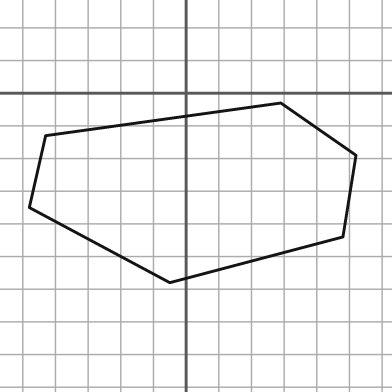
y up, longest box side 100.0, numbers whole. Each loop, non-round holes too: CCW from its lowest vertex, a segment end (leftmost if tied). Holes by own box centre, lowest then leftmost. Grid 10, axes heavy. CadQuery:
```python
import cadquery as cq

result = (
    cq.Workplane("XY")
    .moveTo(-5.0, -58.0)
    .lineTo(48.0, -44.0)
    .lineTo(52.0, -19.0)
    .lineTo(29.0, -3.0)
    .lineTo(-43.0, -13.0)
    .lineTo(-48.0, -35.0)
    .close()
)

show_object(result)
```